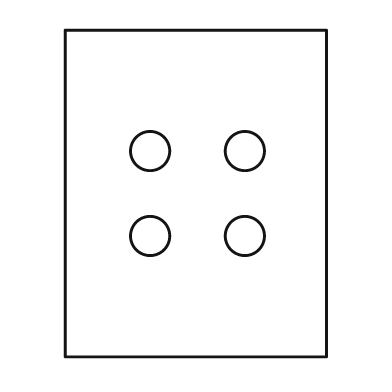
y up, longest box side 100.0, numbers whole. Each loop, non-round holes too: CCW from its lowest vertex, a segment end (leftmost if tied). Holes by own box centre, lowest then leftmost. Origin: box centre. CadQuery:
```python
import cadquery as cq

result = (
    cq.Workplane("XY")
    .moveTo(-40.0, -50.0)
    .lineTo(40.0, -50.0)
    .lineTo(40.0, 50.0)
    .lineTo(-40.0, 50.0)
    .close()
    .moveTo(-14.0, -13.0)
    .circle(6.0)
    .moveTo(15.0, -13.0)
    .circle(6.0)
    .moveTo(-14.0, 13.0)
    .circle(6.0)
    .moveTo(15.0, 13.0)
    .circle(6.0)
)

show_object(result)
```